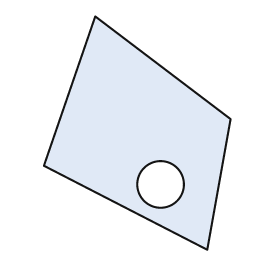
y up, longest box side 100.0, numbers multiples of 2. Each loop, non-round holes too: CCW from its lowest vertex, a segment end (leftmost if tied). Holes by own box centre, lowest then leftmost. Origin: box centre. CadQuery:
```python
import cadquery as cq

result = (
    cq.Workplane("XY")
    .moveTo(30.0, -50.0)
    .lineTo(40.0, 6.0)
    .lineTo(-18.0, 50.0)
    .lineTo(-40.0, -14.0)
    .close()
    .moveTo(10.0, -22.0)
    .circle(10.0)
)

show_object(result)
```